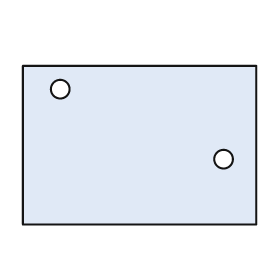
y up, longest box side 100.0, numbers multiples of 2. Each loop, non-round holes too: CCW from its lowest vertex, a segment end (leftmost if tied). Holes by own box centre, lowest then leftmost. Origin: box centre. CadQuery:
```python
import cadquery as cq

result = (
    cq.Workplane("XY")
    .moveTo(-50.0, -34.0)
    .lineTo(50.0, -34.0)
    .lineTo(50.0, 34.0)
    .lineTo(-50.0, 34.0)
    .close()
    .moveTo(36.0, -6.0)
    .circle(4.0)
    .moveTo(-34.0, 24.0)
    .circle(4.0)
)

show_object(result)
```